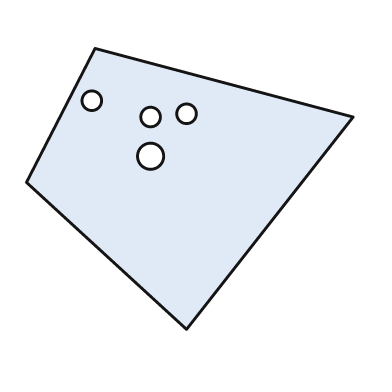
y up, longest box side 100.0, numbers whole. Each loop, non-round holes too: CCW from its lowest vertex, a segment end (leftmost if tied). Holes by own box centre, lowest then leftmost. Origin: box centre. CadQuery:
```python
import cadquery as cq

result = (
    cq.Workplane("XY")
    .moveTo(-1.0, -43.0)
    .lineTo(50.0, 22.0)
    .lineTo(-29.0, 43.0)
    .lineTo(-50.0, 2.0)
    .close()
    .moveTo(-12.0, 10.0)
    .circle(4.0)
    .moveTo(-12.0, 22.0)
    .circle(3.0)
    .moveTo(-1.0, 23.0)
    .circle(3.0)
    .moveTo(-30.0, 27.0)
    .circle(3.0)
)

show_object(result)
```